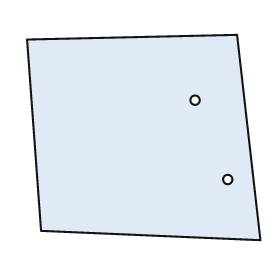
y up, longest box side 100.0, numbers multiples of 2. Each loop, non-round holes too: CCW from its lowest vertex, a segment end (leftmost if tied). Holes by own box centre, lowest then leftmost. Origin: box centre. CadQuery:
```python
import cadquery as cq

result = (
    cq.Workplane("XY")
    .moveTo(50.0, -44.0)
    .lineTo(40.0, 44.0)
    .lineTo(-50.0, 42.0)
    .lineTo(-44.0, -40.0)
    .close()
    .moveTo(36.0, -18.0)
    .circle(2.0)
    .moveTo(22.0, 16.0)
    .circle(2.0)
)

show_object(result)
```